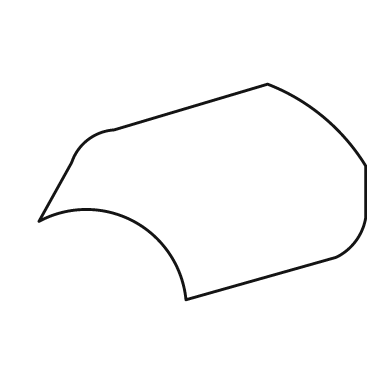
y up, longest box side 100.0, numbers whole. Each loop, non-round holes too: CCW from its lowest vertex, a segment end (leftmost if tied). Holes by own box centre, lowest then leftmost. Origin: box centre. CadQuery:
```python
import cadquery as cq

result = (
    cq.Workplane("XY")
    .moveTo(-5.0, -33.0)
    .lineTo(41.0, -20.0)
    .threePointArc((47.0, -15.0), (50.0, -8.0))
    .lineTo(50.0, 8.0)
    .threePointArc((37.0, 23.0), (20.0, 33.0))
    .lineTo(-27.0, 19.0)
    .threePointArc((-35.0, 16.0), (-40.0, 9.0))
    .lineTo(-50.0, -9.0)
    .threePointArc((-21.0, -9.0), (-5.0, -33.0))
    .close()
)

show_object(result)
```